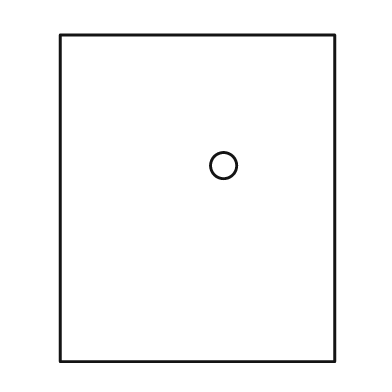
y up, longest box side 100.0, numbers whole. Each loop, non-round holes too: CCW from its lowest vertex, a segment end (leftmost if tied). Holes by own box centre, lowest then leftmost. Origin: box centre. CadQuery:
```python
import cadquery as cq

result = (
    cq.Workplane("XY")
    .moveTo(-42.0, -50.0)
    .lineTo(42.0, -50.0)
    .lineTo(42.0, 50.0)
    .lineTo(-42.0, 50.0)
    .close()
    .moveTo(8.0, 10.0)
    .circle(4.0)
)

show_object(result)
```